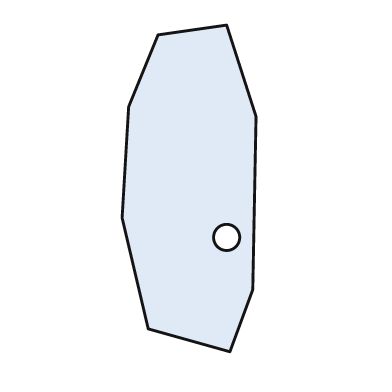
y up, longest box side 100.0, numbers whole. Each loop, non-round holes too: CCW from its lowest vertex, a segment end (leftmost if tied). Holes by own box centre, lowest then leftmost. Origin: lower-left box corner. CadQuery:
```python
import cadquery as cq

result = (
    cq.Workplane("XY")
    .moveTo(33.0, 0.0)
    .lineTo(40.0, 19.0)
    .lineTo(41.0, 72.0)
    .lineTo(32.0, 100.0)
    .lineTo(11.0, 97.0)
    .lineTo(2.0, 75.0)
    .lineTo(0.0, 41.0)
    .lineTo(8.0, 7.0)
    .close()
    .moveTo(32.0, 35.0)
    .circle(4.0)
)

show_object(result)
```